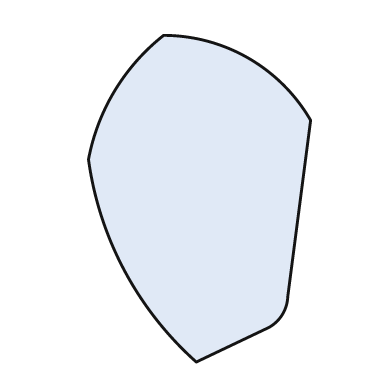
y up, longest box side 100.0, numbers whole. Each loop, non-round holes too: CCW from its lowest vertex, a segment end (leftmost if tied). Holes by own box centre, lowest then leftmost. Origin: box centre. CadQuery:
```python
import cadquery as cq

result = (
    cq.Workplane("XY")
    .moveTo(-1.0, -50.0)
    .lineTo(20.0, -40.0)
    .threePointArc((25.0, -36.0), (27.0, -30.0))
    .lineTo(34.0, 24.0)
    .threePointArc((15.0, 43.0), (-11.0, 50.0))
    .threePointArc((-26.0, 33.0), (-34.0, 12.0))
    .threePointArc((-23.0, -22.0), (-1.0, -50.0))
    .close()
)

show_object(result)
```